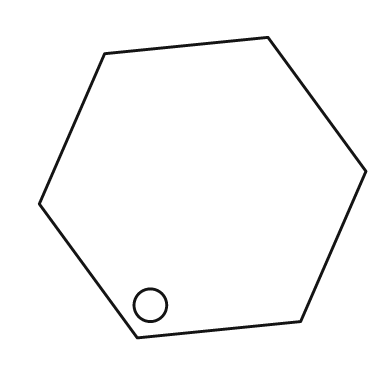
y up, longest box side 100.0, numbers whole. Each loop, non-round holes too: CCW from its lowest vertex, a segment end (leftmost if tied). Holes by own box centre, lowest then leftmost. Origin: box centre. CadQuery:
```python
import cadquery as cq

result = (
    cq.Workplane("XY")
    .moveTo(-20.0, -46.0)
    .lineTo(30.0, -41.0)
    .lineTo(50.0, 5.0)
    .lineTo(20.0, 46.0)
    .lineTo(-30.0, 41.0)
    .lineTo(-50.0, -5.0)
    .close()
    .moveTo(-16.0, -36.0)
    .circle(5.0)
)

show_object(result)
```